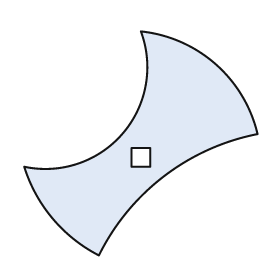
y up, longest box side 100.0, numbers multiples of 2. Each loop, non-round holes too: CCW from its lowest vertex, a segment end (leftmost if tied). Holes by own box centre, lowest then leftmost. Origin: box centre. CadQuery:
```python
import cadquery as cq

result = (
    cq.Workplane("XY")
    .moveTo(-18.0, -48.0)
    .threePointArc((10.0, -14.0), (50.0, 4.0))
    .threePointArc((32.0, 34.0), (0.0, 48.0))
    .threePointArc((-8.0, 4.0), (-50.0, -10.0))
    .threePointArc((-38.0, -32.0), (-18.0, -48.0))
    .close()
    .moveTo(-4.0, -10.0)
    .lineTo(4.0, -10.0)
    .lineTo(4.0, -2.0)
    .lineTo(-4.0, -2.0)
    .close()
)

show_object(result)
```